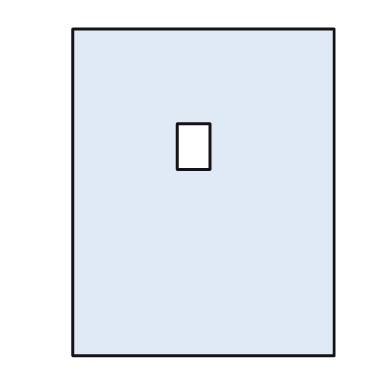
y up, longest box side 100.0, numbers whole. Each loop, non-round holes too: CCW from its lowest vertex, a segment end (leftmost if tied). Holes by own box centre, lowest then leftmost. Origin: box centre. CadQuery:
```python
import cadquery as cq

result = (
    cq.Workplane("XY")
    .moveTo(-40.0, -50.0)
    .lineTo(40.0, -50.0)
    .lineTo(40.0, 50.0)
    .lineTo(-40.0, 50.0)
    .close()
    .moveTo(-8.0, 7.0)
    .lineTo(2.0, 7.0)
    .lineTo(2.0, 21.0)
    .lineTo(-8.0, 21.0)
    .close()
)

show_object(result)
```